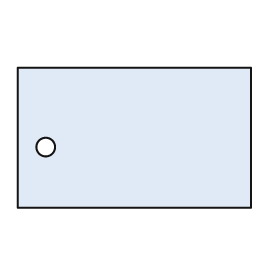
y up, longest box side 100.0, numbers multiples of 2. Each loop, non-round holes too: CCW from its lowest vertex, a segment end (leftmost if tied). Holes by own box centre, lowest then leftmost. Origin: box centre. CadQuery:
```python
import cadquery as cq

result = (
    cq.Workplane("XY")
    .moveTo(-50.0, -30.0)
    .lineTo(50.0, -30.0)
    .lineTo(50.0, 30.0)
    .lineTo(-50.0, 30.0)
    .close()
    .moveTo(-38.0, -4.0)
    .circle(4.0)
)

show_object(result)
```